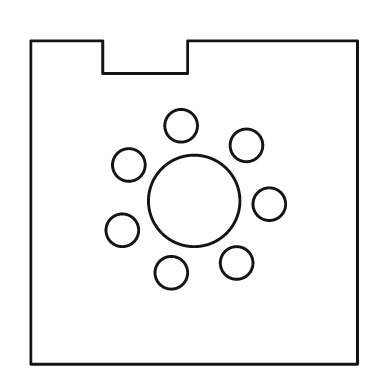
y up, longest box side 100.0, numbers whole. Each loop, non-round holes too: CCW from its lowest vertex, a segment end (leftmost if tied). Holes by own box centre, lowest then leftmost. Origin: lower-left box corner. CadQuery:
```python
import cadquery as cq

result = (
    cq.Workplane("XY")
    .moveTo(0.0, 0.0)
    .lineTo(100.0, 0.0)
    .lineTo(100.0, 99.0)
    .lineTo(48.0, 99.0)
    .lineTo(48.0, 89.0)
    .lineTo(22.0, 89.0)
    .lineTo(22.0, 99.0)
    .lineTo(0.0, 99.0)
    .close()
    .moveTo(43.0, 28.0)
    .circle(5.0)
    .moveTo(63.0, 31.0)
    .circle(5.0)
    .moveTo(28.0, 41.0)
    .circle(5.0)
    .moveTo(73.0, 49.0)
    .circle(5.0)
    .moveTo(50.0, 50.0)
    .circle(14.0)
    .moveTo(30.0, 61.0)
    .circle(5.0)
    .moveTo(66.0, 67.0)
    .circle(5.0)
    .moveTo(46.0, 73.0)
    .circle(5.0)
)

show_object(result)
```